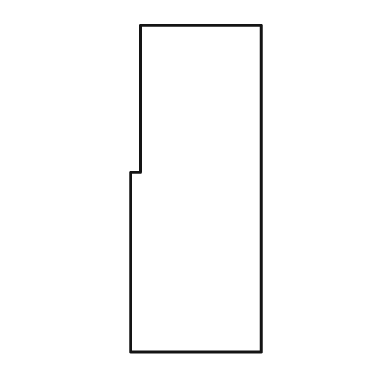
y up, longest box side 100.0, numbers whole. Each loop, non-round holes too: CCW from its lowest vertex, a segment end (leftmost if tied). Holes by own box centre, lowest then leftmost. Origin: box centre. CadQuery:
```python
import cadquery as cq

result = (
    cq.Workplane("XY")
    .moveTo(-20.0, -50.0)
    .lineTo(20.0, -50.0)
    .lineTo(20.0, 50.0)
    .lineTo(-17.0, 50.0)
    .lineTo(-17.0, 5.0)
    .lineTo(-20.0, 5.0)
    .close()
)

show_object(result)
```